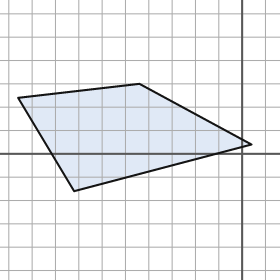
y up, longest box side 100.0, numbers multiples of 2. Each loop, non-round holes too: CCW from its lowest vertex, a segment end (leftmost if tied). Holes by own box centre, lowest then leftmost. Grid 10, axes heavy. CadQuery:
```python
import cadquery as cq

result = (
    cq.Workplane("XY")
    .moveTo(-72.0, -16.0)
    .lineTo(4.0, 4.0)
    .lineTo(-44.0, 30.0)
    .lineTo(-96.0, 24.0)
    .close()
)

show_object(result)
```